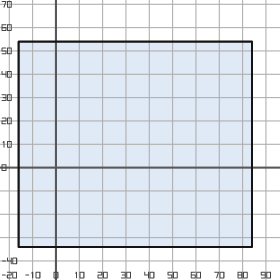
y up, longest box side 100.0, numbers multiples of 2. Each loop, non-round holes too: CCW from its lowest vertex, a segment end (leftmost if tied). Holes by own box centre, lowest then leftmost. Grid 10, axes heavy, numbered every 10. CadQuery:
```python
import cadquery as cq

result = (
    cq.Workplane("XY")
    .moveTo(-16.0, -34.0)
    .lineTo(84.0, -34.0)
    .lineTo(84.0, 54.0)
    .lineTo(-16.0, 54.0)
    .close()
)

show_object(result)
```